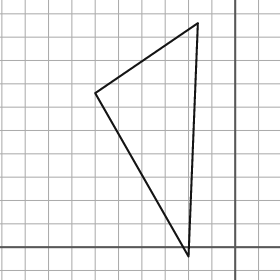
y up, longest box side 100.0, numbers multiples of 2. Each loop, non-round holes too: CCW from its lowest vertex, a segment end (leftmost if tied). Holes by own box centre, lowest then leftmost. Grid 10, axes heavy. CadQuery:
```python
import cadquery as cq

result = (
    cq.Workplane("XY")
    .moveTo(-20.0, -4.0)
    .lineTo(-16.0, 96.0)
    .lineTo(-60.0, 66.0)
    .close()
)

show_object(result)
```